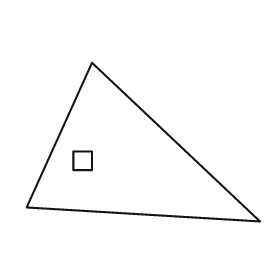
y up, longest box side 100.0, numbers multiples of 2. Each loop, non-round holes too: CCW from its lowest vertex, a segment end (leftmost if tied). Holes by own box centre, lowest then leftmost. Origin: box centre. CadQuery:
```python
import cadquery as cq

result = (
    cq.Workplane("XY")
    .moveTo(50.0, -34.0)
    .lineTo(-22.0, 34.0)
    .lineTo(-50.0, -28.0)
    .close()
    .moveTo(-30.0, -12.0)
    .lineTo(-22.0, -12.0)
    .lineTo(-22.0, -4.0)
    .lineTo(-30.0, -4.0)
    .close()
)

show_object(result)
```